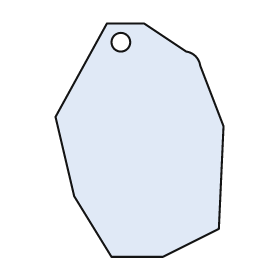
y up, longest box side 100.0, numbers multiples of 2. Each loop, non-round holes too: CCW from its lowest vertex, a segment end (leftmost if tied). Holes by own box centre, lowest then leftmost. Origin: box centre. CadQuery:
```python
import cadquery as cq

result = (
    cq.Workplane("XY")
    .moveTo(-12.0, -50.0)
    .lineTo(10.0, -50.0)
    .lineTo(34.0, -38.0)
    .lineTo(36.0, 6.0)
    .lineTo(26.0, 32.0)
    .threePointArc((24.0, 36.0), (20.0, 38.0))
    .lineTo(2.0, 50.0)
    .lineTo(-14.0, 50.0)
    .lineTo(-36.0, 10.0)
    .lineTo(-28.0, -24.0)
    .close()
    .moveTo(-8.0, 42.0)
    .circle(4.0)
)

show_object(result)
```